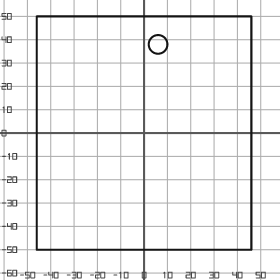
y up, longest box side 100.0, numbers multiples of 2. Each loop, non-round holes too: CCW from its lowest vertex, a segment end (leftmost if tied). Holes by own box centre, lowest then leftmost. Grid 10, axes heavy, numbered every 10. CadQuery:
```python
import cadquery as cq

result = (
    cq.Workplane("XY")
    .moveTo(-46.0, -50.0)
    .lineTo(46.0, -50.0)
    .lineTo(46.0, 50.0)
    .lineTo(-46.0, 50.0)
    .close()
    .moveTo(6.0, 38.0)
    .circle(4.0)
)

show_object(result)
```